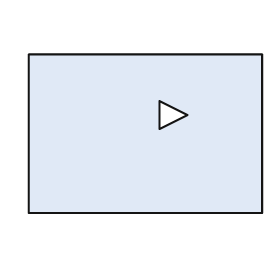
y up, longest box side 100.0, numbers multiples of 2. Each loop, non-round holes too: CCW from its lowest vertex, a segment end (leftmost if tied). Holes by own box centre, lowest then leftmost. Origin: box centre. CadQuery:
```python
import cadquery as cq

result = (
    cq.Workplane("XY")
    .moveTo(-50.0, -34.0)
    .lineTo(50.0, -34.0)
    .lineTo(50.0, 34.0)
    .lineTo(-50.0, 34.0)
    .close()
    .moveTo(6.0, 2.0)
    .lineTo(18.0, 8.0)
    .lineTo(6.0, 14.0)
    .close()
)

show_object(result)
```